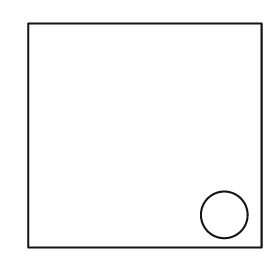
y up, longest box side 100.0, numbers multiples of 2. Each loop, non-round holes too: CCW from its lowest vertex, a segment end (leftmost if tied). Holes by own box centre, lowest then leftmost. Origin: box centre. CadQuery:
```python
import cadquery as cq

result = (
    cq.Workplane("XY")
    .moveTo(-50.0, -48.0)
    .lineTo(50.0, -48.0)
    .lineTo(50.0, 48.0)
    .lineTo(-50.0, 48.0)
    .close()
    .moveTo(34.0, -34.0)
    .circle(10.0)
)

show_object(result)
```